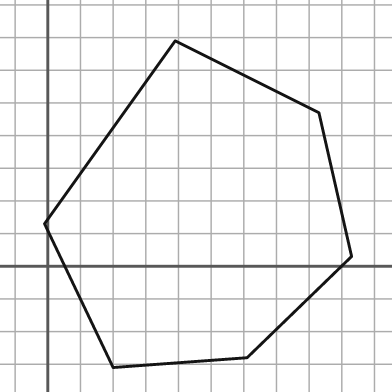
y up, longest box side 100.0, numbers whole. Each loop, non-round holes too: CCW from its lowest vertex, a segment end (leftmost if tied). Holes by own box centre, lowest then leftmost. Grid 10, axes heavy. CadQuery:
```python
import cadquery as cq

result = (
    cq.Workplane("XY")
    .moveTo(20.0, -31.0)
    .lineTo(61.0, -28.0)
    .lineTo(93.0, 3.0)
    .lineTo(83.0, 47.0)
    .lineTo(39.0, 69.0)
    .lineTo(-1.0, 13.0)
    .close()
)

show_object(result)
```